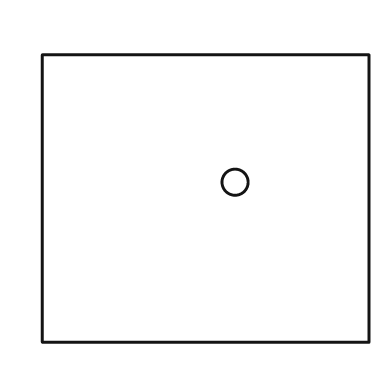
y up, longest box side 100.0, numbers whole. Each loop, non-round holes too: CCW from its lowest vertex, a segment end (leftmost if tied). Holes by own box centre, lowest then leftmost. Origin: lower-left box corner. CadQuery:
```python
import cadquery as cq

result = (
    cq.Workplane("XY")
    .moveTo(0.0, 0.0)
    .lineTo(100.0, 0.0)
    .lineTo(100.0, 88.0)
    .lineTo(0.0, 88.0)
    .close()
    .moveTo(59.0, 49.0)
    .circle(4.0)
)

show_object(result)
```